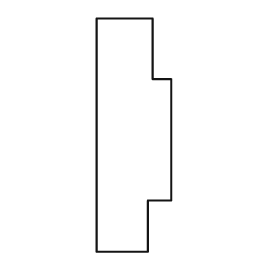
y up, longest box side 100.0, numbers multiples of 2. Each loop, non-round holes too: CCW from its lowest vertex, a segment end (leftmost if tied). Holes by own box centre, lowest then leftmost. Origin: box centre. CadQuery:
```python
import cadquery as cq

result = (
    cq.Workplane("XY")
    .moveTo(-16.0, -50.0)
    .lineTo(6.0, -50.0)
    .lineTo(6.0, -28.0)
    .lineTo(16.0, -28.0)
    .lineTo(16.0, 24.0)
    .lineTo(8.0, 24.0)
    .lineTo(8.0, 50.0)
    .lineTo(-16.0, 50.0)
    .close()
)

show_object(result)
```